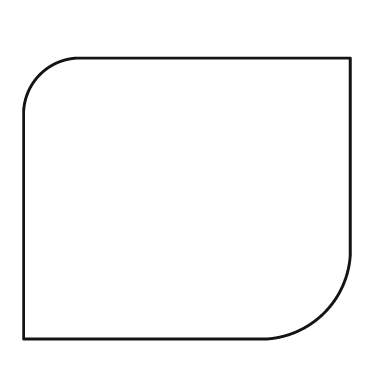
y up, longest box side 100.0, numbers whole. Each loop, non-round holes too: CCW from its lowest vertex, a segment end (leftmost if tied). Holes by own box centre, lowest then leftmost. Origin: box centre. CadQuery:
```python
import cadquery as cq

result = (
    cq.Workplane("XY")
    .moveTo(-50.0, -43.0)
    .lineTo(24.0, -43.0)
    .threePointArc((42.0, -35.0), (50.0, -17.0))
    .lineTo(50.0, 43.0)
    .lineTo(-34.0, 43.0)
    .threePointArc((-45.0, 38.0), (-50.0, 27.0))
    .close()
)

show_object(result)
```